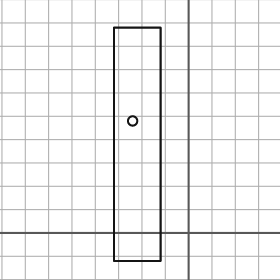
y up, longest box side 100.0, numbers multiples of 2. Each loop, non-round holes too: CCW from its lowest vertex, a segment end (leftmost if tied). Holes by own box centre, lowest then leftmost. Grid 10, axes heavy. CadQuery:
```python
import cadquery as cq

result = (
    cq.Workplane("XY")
    .moveTo(-32.0, -12.0)
    .lineTo(-12.0, -12.0)
    .lineTo(-12.0, 88.0)
    .lineTo(-32.0, 88.0)
    .close()
    .moveTo(-24.0, 48.0)
    .circle(2.0)
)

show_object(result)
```